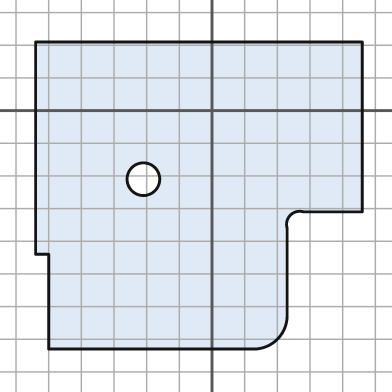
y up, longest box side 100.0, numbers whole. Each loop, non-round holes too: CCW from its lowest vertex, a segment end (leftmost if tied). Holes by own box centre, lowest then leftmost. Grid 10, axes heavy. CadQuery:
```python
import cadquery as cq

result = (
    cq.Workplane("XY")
    .moveTo(-50.0, -73.0)
    .lineTo(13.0, -73.0)
    .threePointArc((20.0, -70.0), (23.0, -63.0))
    .lineTo(23.0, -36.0)
    .threePointArc((24.0, -32.0), (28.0, -31.0))
    .lineTo(46.0, -31.0)
    .lineTo(46.0, 21.0)
    .lineTo(-54.0, 21.0)
    .lineTo(-54.0, -44.0)
    .lineTo(-50.0, -44.0)
    .close()
    .moveTo(-21.0, -21.0)
    .circle(5.0)
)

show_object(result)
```